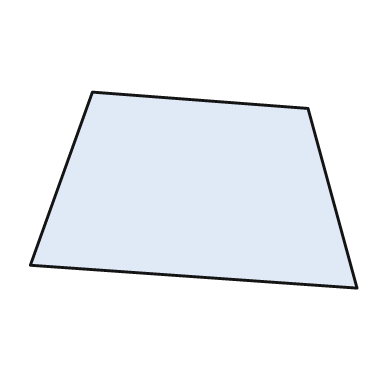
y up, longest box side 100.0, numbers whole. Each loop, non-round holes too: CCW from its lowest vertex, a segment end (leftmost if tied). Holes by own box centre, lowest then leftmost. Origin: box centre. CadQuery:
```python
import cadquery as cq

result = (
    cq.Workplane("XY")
    .moveTo(50.0, -30.0)
    .lineTo(35.0, 25.0)
    .lineTo(-31.0, 30.0)
    .lineTo(-50.0, -23.0)
    .close()
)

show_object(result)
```